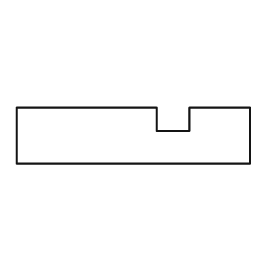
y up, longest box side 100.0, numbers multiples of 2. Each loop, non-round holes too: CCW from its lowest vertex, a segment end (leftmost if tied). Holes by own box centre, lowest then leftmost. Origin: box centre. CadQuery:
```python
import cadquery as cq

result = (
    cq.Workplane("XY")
    .moveTo(-50.0, -12.0)
    .lineTo(50.0, -12.0)
    .lineTo(50.0, 12.0)
    .lineTo(24.0, 12.0)
    .lineTo(24.0, 2.0)
    .lineTo(10.0, 2.0)
    .lineTo(10.0, 12.0)
    .lineTo(-50.0, 12.0)
    .close()
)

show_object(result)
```